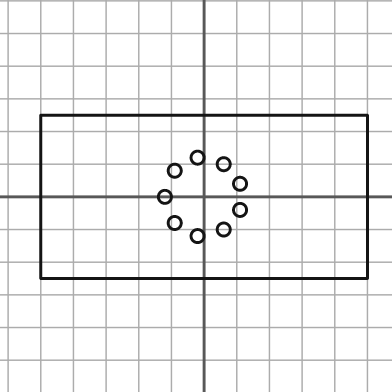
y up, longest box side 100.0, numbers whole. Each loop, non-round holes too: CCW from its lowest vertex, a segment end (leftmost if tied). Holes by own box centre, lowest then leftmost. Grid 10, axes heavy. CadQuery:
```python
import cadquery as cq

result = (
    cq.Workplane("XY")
    .moveTo(-50.0, -25.0)
    .lineTo(50.0, -25.0)
    .lineTo(50.0, 25.0)
    .lineTo(-50.0, 25.0)
    .close()
    .moveTo(-2.0, -12.0)
    .circle(2.0)
    .moveTo(6.0, -10.0)
    .circle(2.0)
    .moveTo(-9.0, -8.0)
    .circle(2.0)
    .moveTo(11.0, -4.0)
    .circle(2.0)
    .moveTo(-12.0, 0.0)
    .circle(2.0)
    .moveTo(11.0, 4.0)
    .circle(2.0)
    .moveTo(-9.0, 8.0)
    .circle(2.0)
    .moveTo(6.0, 10.0)
    .circle(2.0)
    .moveTo(-2.0, 12.0)
    .circle(2.0)
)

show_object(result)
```